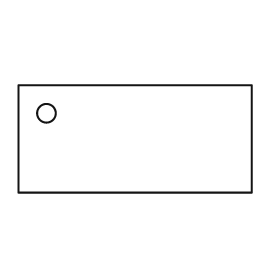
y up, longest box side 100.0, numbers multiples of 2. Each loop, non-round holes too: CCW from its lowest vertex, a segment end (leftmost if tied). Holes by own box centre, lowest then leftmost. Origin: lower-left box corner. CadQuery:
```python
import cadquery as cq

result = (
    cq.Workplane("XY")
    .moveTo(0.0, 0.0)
    .lineTo(100.0, 0.0)
    .lineTo(100.0, 46.0)
    .lineTo(0.0, 46.0)
    .close()
    .moveTo(12.0, 34.0)
    .circle(4.0)
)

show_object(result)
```